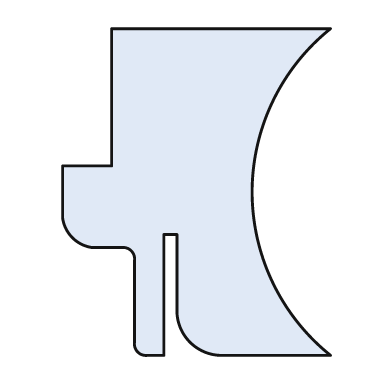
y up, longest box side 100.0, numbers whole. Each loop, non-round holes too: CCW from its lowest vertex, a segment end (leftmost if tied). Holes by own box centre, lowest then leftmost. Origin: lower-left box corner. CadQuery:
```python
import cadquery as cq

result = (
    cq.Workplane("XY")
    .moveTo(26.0, 0.0)
    .lineTo(31.0, 0.0)
    .lineTo(31.0, 37.0)
    .lineTo(35.0, 37.0)
    .lineTo(35.0, 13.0)
    .threePointArc((39.0, 4.0), (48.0, 0.0))
    .lineTo(82.0, 0.0)
    .threePointArc((58.0, 50.0), (82.0, 100.0))
    .lineTo(15.0, 100.0)
    .lineTo(15.0, 58.0)
    .lineTo(0.0, 58.0)
    .lineTo(0.0, 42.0)
    .threePointArc((3.0, 36.0), (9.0, 33.0))
    .lineTo(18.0, 33.0)
    .threePointArc((21.0, 32.0), (22.0, 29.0))
    .lineTo(22.0, 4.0)
    .threePointArc((23.0, 1.0), (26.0, 0.0))
    .close()
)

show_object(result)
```